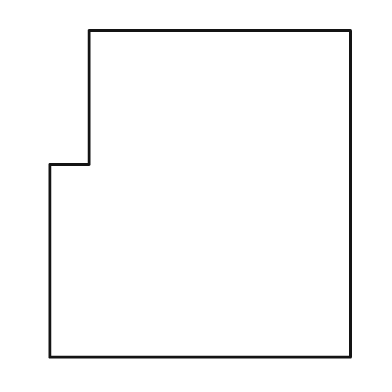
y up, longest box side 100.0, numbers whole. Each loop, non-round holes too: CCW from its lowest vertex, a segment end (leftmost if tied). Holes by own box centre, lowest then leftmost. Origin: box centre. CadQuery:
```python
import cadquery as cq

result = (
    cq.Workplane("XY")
    .moveTo(-46.0, -50.0)
    .lineTo(46.0, -50.0)
    .lineTo(46.0, 50.0)
    .lineTo(-34.0, 50.0)
    .lineTo(-34.0, 9.0)
    .lineTo(-46.0, 9.0)
    .close()
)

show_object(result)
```